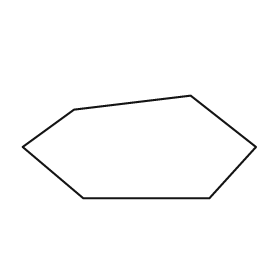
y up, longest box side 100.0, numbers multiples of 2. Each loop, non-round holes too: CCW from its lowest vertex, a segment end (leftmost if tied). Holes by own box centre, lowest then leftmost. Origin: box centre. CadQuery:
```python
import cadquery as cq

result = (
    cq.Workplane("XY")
    .moveTo(-24.0, -22.0)
    .lineTo(30.0, -22.0)
    .lineTo(50.0, 0.0)
    .lineTo(22.0, 22.0)
    .lineTo(-28.0, 16.0)
    .lineTo(-50.0, 0.0)
    .close()
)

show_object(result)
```